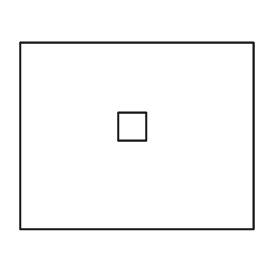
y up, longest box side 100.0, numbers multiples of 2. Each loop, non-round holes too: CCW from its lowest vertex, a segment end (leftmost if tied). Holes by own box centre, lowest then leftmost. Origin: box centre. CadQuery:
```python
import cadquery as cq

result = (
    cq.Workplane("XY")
    .moveTo(-50.0, -40.0)
    .lineTo(50.0, -40.0)
    .lineTo(50.0, 40.0)
    .lineTo(-50.0, 40.0)
    .close()
    .moveTo(-8.0, -2.0)
    .lineTo(4.0, -2.0)
    .lineTo(4.0, 10.0)
    .lineTo(-8.0, 10.0)
    .close()
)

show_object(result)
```